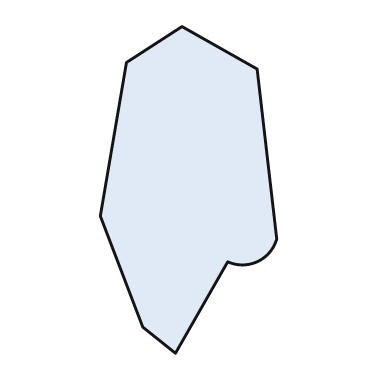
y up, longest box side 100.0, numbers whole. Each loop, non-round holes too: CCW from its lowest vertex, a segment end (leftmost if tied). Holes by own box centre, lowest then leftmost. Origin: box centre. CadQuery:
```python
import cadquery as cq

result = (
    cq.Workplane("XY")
    .moveTo(-4.0, -50.0)
    .lineTo(12.0, -22.0)
    .threePointArc((21.0, -22.0), (27.0, -15.0))
    .lineTo(21.0, 37.0)
    .lineTo(-2.0, 50.0)
    .lineTo(-19.0, 39.0)
    .lineTo(-27.0, -8.0)
    .lineTo(-14.0, -42.0)
    .close()
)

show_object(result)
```